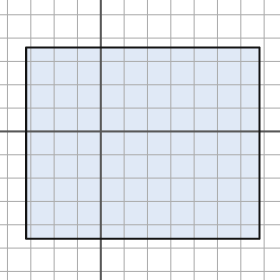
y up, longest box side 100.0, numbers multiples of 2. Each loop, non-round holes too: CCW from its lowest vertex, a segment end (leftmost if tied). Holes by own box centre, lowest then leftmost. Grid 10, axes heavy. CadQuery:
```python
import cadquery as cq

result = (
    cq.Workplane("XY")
    .moveTo(-32.0, -46.0)
    .lineTo(68.0, -46.0)
    .lineTo(68.0, 36.0)
    .lineTo(-32.0, 36.0)
    .close()
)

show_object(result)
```